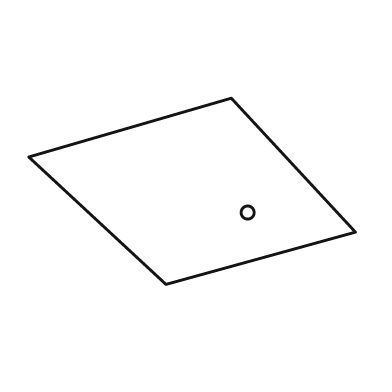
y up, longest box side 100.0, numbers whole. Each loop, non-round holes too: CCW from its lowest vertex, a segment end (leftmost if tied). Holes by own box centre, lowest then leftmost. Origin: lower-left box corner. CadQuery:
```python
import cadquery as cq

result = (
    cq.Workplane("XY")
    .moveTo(42.0, 0.0)
    .lineTo(100.0, 16.0)
    .lineTo(62.0, 57.0)
    .lineTo(0.0, 39.0)
    .close()
    .moveTo(67.0, 22.0)
    .circle(2.0)
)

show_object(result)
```